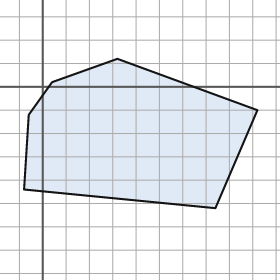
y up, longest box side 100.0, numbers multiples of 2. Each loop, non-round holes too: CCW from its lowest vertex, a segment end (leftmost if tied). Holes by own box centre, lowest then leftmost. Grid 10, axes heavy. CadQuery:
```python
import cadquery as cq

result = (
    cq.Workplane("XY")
    .moveTo(74.0, -52.0)
    .lineTo(92.0, -10.0)
    .lineTo(32.0, 12.0)
    .lineTo(4.0, 2.0)
    .lineTo(-6.0, -12.0)
    .lineTo(-8.0, -44.0)
    .close()
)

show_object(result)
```